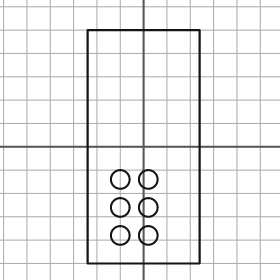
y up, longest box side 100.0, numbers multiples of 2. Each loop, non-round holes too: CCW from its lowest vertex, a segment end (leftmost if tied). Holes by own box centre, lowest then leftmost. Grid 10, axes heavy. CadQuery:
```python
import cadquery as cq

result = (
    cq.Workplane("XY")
    .moveTo(-24.0, -50.0)
    .lineTo(24.0, -50.0)
    .lineTo(24.0, 50.0)
    .lineTo(-24.0, 50.0)
    .close()
    .moveTo(-10.0, -38.0)
    .circle(4.0)
    .moveTo(2.0, -38.0)
    .circle(4.0)
    .moveTo(-10.0, -26.0)
    .circle(4.0)
    .moveTo(2.0, -26.0)
    .circle(4.0)
    .moveTo(-10.0, -14.0)
    .circle(4.0)
    .moveTo(2.0, -14.0)
    .circle(4.0)
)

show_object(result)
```